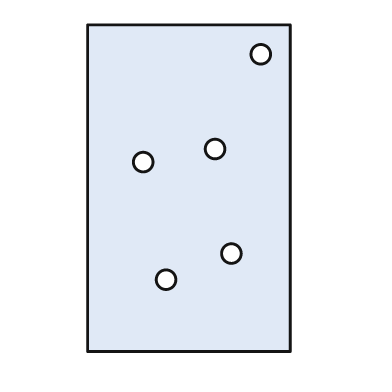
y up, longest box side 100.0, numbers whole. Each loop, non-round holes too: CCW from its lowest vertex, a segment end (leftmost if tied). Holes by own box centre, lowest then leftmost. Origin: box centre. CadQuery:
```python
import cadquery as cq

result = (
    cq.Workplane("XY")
    .moveTo(-31.0, -50.0)
    .lineTo(31.0, -50.0)
    .lineTo(31.0, 50.0)
    .lineTo(-31.0, 50.0)
    .close()
    .moveTo(-7.0, -28.0)
    .circle(3.0)
    .moveTo(13.0, -20.0)
    .circle(3.0)
    .moveTo(-14.0, 8.0)
    .circle(3.0)
    .moveTo(8.0, 12.0)
    .circle(3.0)
    .moveTo(22.0, 41.0)
    .circle(3.0)
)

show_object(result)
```